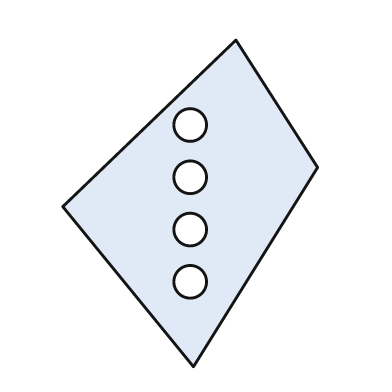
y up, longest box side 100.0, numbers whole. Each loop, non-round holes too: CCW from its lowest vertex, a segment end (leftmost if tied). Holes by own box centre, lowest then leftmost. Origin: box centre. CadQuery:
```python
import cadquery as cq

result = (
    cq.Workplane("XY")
    .moveTo(1.0, -50.0)
    .lineTo(39.0, 11.0)
    .lineTo(14.0, 50.0)
    .lineTo(-39.0, -1.0)
    .close()
    .moveTo(0.0, -24.0)
    .circle(5.0)
    .moveTo(0.0, -8.0)
    .circle(5.0)
    .moveTo(0.0, 8.0)
    .circle(5.0)
    .moveTo(0.0, 24.0)
    .circle(5.0)
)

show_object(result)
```